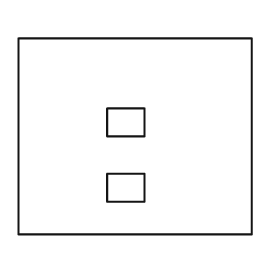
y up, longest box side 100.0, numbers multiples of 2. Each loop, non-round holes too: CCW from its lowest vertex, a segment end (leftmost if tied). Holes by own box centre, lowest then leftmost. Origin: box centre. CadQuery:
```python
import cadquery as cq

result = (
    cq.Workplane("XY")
    .moveTo(-50.0, -42.0)
    .lineTo(50.0, -42.0)
    .lineTo(50.0, 42.0)
    .lineTo(-50.0, 42.0)
    .close()
    .moveTo(-12.0, -28.0)
    .lineTo(4.0, -28.0)
    .lineTo(4.0, -16.0)
    .lineTo(-12.0, -16.0)
    .close()
    .moveTo(-12.0, 0.0)
    .lineTo(4.0, 0.0)
    .lineTo(4.0, 12.0)
    .lineTo(-12.0, 12.0)
    .close()
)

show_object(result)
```